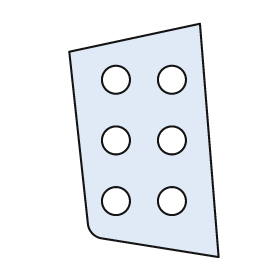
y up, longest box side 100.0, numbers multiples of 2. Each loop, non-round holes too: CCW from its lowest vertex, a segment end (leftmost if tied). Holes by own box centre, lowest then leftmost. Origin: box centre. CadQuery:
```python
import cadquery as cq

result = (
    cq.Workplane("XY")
    .moveTo(32.0, -50.0)
    .lineTo(24.0, 50.0)
    .lineTo(-32.0, 38.0)
    .lineTo(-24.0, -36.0)
    .threePointArc((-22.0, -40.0), (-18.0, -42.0))
    .close()
    .moveTo(-12.0, -26.0)
    .circle(6.0)
    .moveTo(12.0, -26.0)
    .circle(6.0)
    .moveTo(-12.0, 0.0)
    .circle(6.0)
    .moveTo(12.0, 0.0)
    .circle(6.0)
    .moveTo(-12.0, 26.0)
    .circle(6.0)
    .moveTo(12.0, 26.0)
    .circle(6.0)
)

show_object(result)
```